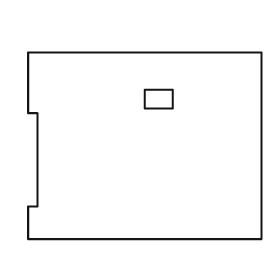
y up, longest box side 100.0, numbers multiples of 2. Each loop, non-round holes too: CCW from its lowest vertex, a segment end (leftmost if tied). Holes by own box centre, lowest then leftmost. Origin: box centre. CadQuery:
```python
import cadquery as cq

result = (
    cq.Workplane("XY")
    .moveTo(-50.0, -40.0)
    .lineTo(50.0, -40.0)
    .lineTo(50.0, 40.0)
    .lineTo(-50.0, 40.0)
    .lineTo(-50.0, 14.0)
    .lineTo(-46.0, 14.0)
    .lineTo(-46.0, -26.0)
    .lineTo(-50.0, -26.0)
    .close()
    .moveTo(0.0, 16.0)
    .lineTo(12.0, 16.0)
    .lineTo(12.0, 24.0)
    .lineTo(0.0, 24.0)
    .close()
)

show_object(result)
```